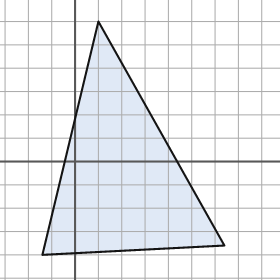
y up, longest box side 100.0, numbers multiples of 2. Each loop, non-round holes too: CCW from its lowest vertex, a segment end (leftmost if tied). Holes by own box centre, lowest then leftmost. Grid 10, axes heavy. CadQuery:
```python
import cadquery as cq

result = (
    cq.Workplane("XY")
    .moveTo(-14.0, -40.0)
    .lineTo(64.0, -36.0)
    .lineTo(10.0, 60.0)
    .close()
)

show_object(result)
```